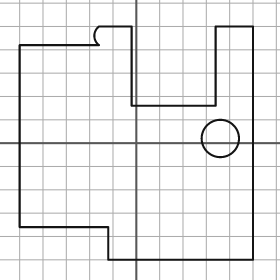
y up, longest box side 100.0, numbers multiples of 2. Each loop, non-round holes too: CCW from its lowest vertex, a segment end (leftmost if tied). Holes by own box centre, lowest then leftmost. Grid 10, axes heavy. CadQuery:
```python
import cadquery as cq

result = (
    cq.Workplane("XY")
    .moveTo(-12.0, -50.0)
    .lineTo(50.0, -50.0)
    .lineTo(50.0, 50.0)
    .lineTo(34.0, 50.0)
    .lineTo(34.0, 16.0)
    .lineTo(-2.0, 16.0)
    .lineTo(-2.0, 50.0)
    .lineTo(-16.0, 50.0)
    .threePointArc((-18.0, 46.0), (-16.0, 42.0))
    .lineTo(-50.0, 42.0)
    .lineTo(-50.0, -36.0)
    .lineTo(-12.0, -36.0)
    .close()
    .moveTo(36.0, 2.0)
    .circle(8.0)
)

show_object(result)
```